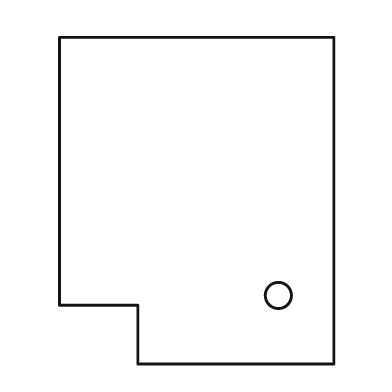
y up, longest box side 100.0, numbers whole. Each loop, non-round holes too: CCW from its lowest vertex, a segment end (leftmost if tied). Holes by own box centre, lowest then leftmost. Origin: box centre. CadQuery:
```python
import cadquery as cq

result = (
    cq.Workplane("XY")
    .moveTo(-18.0, -50.0)
    .lineTo(42.0, -50.0)
    .lineTo(42.0, 50.0)
    .lineTo(-42.0, 50.0)
    .lineTo(-42.0, -32.0)
    .lineTo(-18.0, -32.0)
    .close()
    .moveTo(25.0, -29.0)
    .circle(4.0)
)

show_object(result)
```